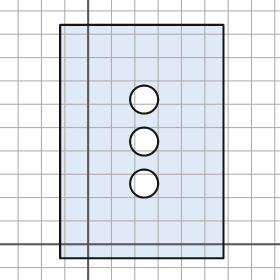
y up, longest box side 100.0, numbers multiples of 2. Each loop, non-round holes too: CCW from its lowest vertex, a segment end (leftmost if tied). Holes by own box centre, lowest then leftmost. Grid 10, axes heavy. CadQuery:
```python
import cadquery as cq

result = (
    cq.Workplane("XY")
    .moveTo(-12.0, -6.0)
    .lineTo(58.0, -6.0)
    .lineTo(58.0, 94.0)
    .lineTo(-12.0, 94.0)
    .close()
    .moveTo(24.0, 26.0)
    .circle(6.0)
    .moveTo(24.0, 44.0)
    .circle(6.0)
    .moveTo(24.0, 62.0)
    .circle(6.0)
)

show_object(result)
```